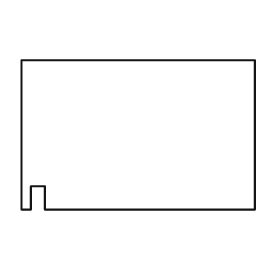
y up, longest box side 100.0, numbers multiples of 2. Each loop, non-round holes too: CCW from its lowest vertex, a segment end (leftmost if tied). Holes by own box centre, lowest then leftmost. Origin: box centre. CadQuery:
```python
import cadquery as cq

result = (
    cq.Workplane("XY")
    .moveTo(-50.0, -32.0)
    .lineTo(-46.0, -32.0)
    .lineTo(-46.0, -22.0)
    .lineTo(-40.0, -22.0)
    .lineTo(-40.0, -32.0)
    .lineTo(50.0, -32.0)
    .lineTo(50.0, 32.0)
    .lineTo(-50.0, 32.0)
    .close()
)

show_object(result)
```